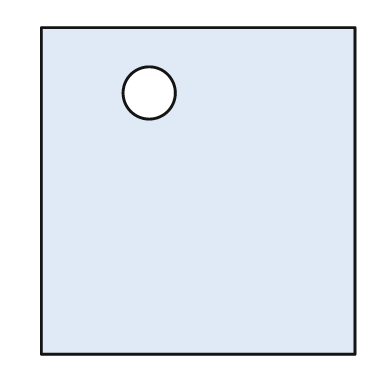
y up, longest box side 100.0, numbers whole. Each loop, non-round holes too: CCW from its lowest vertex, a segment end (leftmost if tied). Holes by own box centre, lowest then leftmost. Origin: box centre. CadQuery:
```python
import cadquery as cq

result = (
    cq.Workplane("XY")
    .moveTo(-48.0, -50.0)
    .lineTo(48.0, -50.0)
    .lineTo(48.0, 50.0)
    .lineTo(-48.0, 50.0)
    .close()
    .moveTo(-15.0, 30.0)
    .circle(8.0)
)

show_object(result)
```